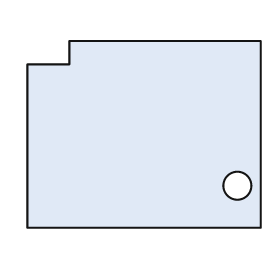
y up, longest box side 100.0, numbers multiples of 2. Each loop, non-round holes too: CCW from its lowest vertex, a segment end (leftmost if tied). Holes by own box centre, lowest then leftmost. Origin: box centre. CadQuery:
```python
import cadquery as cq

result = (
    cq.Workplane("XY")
    .moveTo(-50.0, -40.0)
    .lineTo(50.0, -40.0)
    .lineTo(50.0, 40.0)
    .lineTo(-32.0, 40.0)
    .lineTo(-32.0, 30.0)
    .lineTo(-50.0, 30.0)
    .close()
    .moveTo(40.0, -22.0)
    .circle(6.0)
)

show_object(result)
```